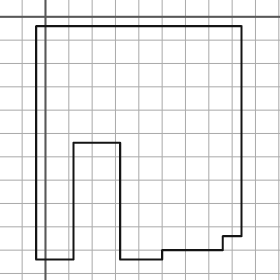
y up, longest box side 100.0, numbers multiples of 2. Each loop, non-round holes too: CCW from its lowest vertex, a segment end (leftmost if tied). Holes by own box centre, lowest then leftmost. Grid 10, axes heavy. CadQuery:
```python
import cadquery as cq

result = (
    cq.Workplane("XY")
    .moveTo(-4.0, -104.0)
    .lineTo(12.0, -104.0)
    .lineTo(12.0, -54.0)
    .lineTo(32.0, -54.0)
    .lineTo(32.0, -104.0)
    .lineTo(50.0, -104.0)
    .lineTo(50.0, -100.0)
    .lineTo(76.0, -100.0)
    .lineTo(76.0, -94.0)
    .lineTo(84.0, -94.0)
    .lineTo(84.0, -4.0)
    .lineTo(-4.0, -4.0)
    .close()
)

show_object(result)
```